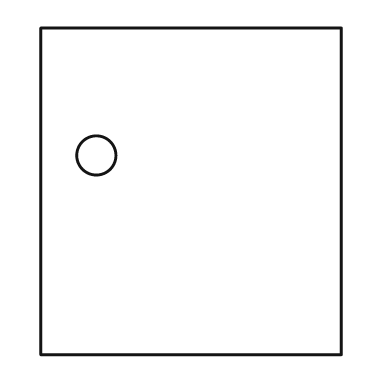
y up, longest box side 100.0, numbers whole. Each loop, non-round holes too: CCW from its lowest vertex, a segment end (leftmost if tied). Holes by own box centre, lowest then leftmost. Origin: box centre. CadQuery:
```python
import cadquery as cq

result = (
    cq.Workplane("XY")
    .moveTo(-46.0, -50.0)
    .lineTo(46.0, -50.0)
    .lineTo(46.0, 50.0)
    .lineTo(-46.0, 50.0)
    .close()
    .moveTo(-29.0, 11.0)
    .circle(6.0)
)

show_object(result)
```